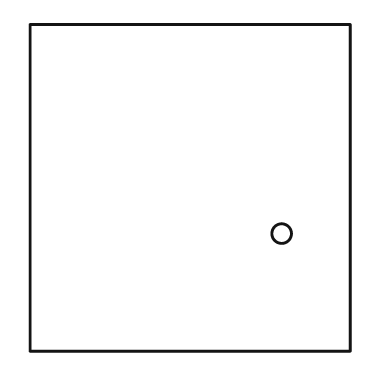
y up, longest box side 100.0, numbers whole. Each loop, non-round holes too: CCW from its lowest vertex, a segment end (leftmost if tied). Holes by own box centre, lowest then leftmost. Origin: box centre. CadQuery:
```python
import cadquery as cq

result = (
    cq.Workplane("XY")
    .moveTo(-49.0, -50.0)
    .lineTo(49.0, -50.0)
    .lineTo(49.0, 50.0)
    .lineTo(-49.0, 50.0)
    .close()
    .moveTo(28.0, -14.0)
    .circle(3.0)
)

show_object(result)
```